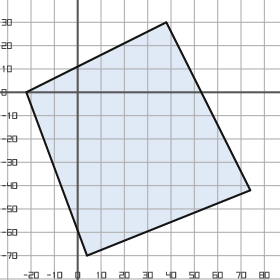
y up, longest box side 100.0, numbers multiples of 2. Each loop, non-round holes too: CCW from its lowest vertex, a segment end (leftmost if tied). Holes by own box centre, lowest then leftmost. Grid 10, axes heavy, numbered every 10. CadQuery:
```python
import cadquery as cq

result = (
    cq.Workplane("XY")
    .moveTo(4.0, -70.0)
    .lineTo(74.0, -42.0)
    .lineTo(38.0, 30.0)
    .lineTo(-22.0, 0.0)
    .close()
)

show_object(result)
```